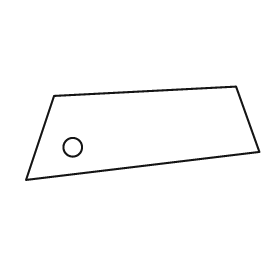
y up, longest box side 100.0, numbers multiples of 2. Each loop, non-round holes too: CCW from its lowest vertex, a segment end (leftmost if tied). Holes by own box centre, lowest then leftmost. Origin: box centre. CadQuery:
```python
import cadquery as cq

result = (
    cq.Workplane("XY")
    .moveTo(-50.0, -20.0)
    .lineTo(50.0, -8.0)
    .lineTo(40.0, 20.0)
    .lineTo(-38.0, 16.0)
    .close()
    .moveTo(-30.0, -6.0)
    .circle(4.0)
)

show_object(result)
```